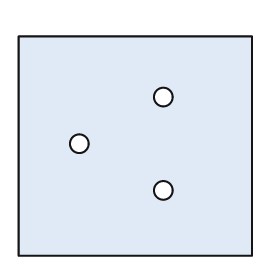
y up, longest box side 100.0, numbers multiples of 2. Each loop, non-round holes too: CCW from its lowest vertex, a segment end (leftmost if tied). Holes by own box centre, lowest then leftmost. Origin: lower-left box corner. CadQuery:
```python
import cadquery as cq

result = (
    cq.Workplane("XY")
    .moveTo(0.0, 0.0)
    .lineTo(100.0, 0.0)
    .lineTo(100.0, 94.0)
    .lineTo(0.0, 94.0)
    .close()
    .moveTo(62.0, 28.0)
    .circle(4.0)
    .moveTo(26.0, 48.0)
    .circle(4.0)
    .moveTo(62.0, 68.0)
    .circle(4.0)
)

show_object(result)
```